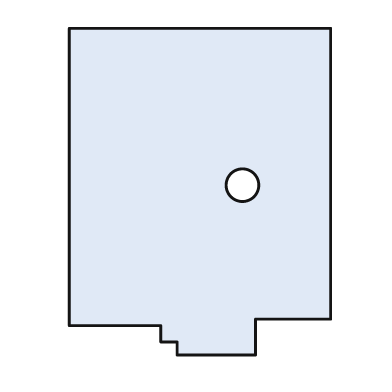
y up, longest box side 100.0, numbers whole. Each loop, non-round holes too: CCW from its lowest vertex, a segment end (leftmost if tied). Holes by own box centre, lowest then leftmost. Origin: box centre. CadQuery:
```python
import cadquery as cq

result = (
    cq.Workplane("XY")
    .moveTo(-7.0, -50.0)
    .lineTo(17.0, -50.0)
    .lineTo(17.0, -39.0)
    .lineTo(40.0, -39.0)
    .lineTo(40.0, 50.0)
    .lineTo(-40.0, 50.0)
    .lineTo(-40.0, -41.0)
    .lineTo(-12.0, -41.0)
    .lineTo(-12.0, -46.0)
    .lineTo(-7.0, -46.0)
    .close()
    .moveTo(13.0, 2.0)
    .circle(5.0)
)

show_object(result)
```